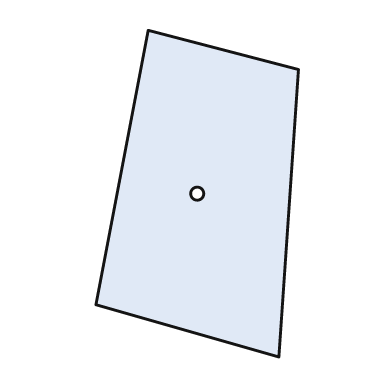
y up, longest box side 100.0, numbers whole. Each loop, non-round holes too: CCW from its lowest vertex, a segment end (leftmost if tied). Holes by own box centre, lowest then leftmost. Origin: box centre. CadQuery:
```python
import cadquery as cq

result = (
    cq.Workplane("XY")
    .moveTo(25.0, -50.0)
    .lineTo(31.0, 38.0)
    .lineTo(-15.0, 50.0)
    .lineTo(-31.0, -34.0)
    .close()
    .moveTo(0.0, 0.0)
    .circle(2.0)
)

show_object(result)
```